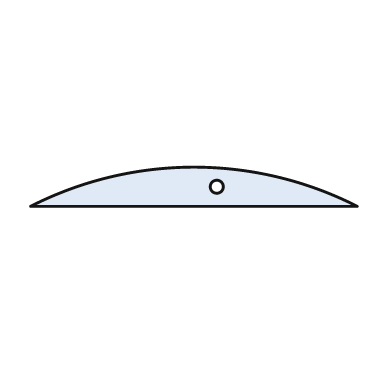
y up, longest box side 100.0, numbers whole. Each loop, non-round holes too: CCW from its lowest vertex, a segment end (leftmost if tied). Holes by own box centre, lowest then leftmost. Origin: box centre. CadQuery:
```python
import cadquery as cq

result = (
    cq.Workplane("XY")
    .moveTo(-50.0, -6.0)
    .lineTo(50.0, -6.0)
    .threePointArc((0.0, 6.0), (-50.0, -6.0))
    .close()
    .moveTo(7.0, 0.0)
    .circle(2.0)
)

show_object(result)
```